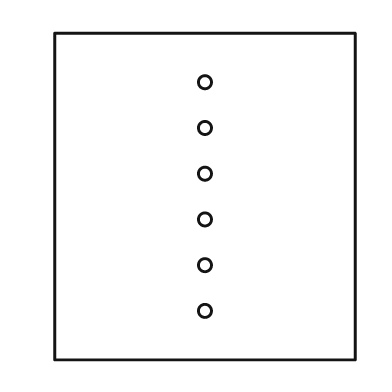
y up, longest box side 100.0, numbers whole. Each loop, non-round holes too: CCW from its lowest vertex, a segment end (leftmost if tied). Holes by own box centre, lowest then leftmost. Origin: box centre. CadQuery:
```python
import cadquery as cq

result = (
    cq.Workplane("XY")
    .moveTo(-46.0, -50.0)
    .lineTo(46.0, -50.0)
    .lineTo(46.0, 50.0)
    .lineTo(-46.0, 50.0)
    .close()
    .moveTo(0.0, -35.0)
    .circle(2.0)
    .moveTo(0.0, -21.0)
    .circle(2.0)
    .moveTo(0.0, -7.0)
    .circle(2.0)
    .moveTo(0.0, 7.0)
    .circle(2.0)
    .moveTo(0.0, 21.0)
    .circle(2.0)
    .moveTo(0.0, 35.0)
    .circle(2.0)
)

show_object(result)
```